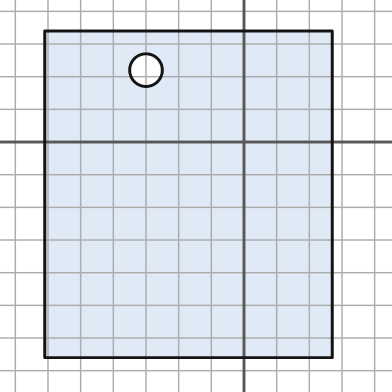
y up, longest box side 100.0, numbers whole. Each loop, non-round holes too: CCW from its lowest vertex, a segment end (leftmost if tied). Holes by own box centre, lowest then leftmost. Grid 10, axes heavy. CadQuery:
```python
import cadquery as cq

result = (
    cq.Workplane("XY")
    .moveTo(-61.0, -66.0)
    .lineTo(27.0, -66.0)
    .lineTo(27.0, 34.0)
    .lineTo(-61.0, 34.0)
    .close()
    .moveTo(-30.0, 22.0)
    .circle(5.0)
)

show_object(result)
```